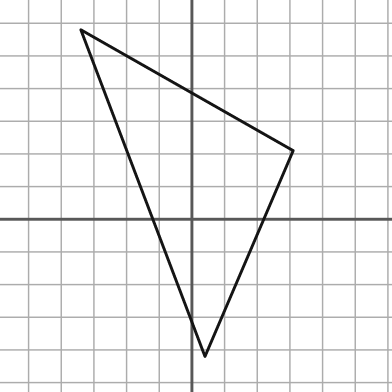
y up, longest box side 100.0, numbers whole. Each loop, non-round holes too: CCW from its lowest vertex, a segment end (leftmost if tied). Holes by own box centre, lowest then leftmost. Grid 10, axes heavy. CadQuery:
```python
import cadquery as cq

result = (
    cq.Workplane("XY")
    .moveTo(4.0, -42.0)
    .lineTo(31.0, 21.0)
    .lineTo(-34.0, 58.0)
    .close()
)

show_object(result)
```